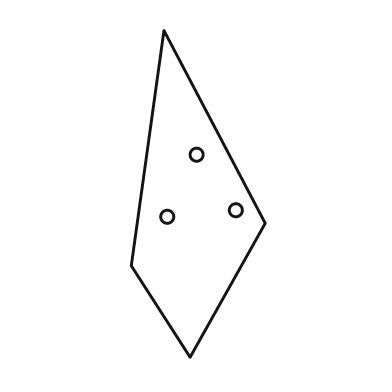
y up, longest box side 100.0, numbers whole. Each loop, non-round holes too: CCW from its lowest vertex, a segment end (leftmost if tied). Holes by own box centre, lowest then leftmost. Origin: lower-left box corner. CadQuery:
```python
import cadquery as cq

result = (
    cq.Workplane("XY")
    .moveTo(18.0, 0.0)
    .lineTo(41.0, 41.0)
    .lineTo(10.0, 100.0)
    .lineTo(0.0, 28.0)
    .close()
    .moveTo(11.0, 43.0)
    .circle(2.0)
    .moveTo(32.0, 45.0)
    .circle(2.0)
    .moveTo(20.0, 62.0)
    .circle(2.0)
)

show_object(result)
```